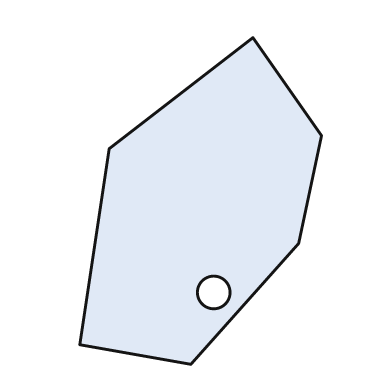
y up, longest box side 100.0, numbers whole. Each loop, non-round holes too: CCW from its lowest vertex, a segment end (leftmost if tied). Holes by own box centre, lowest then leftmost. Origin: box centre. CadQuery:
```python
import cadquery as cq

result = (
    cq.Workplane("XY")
    .moveTo(-3.0, -50.0)
    .lineTo(30.0, -13.0)
    .lineTo(37.0, 20.0)
    .lineTo(16.0, 50.0)
    .lineTo(-28.0, 16.0)
    .lineTo(-37.0, -44.0)
    .close()
    .moveTo(4.0, -28.0)
    .circle(5.0)
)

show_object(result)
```